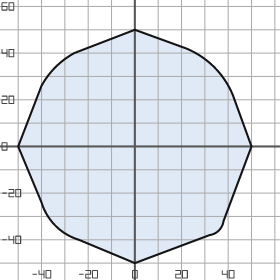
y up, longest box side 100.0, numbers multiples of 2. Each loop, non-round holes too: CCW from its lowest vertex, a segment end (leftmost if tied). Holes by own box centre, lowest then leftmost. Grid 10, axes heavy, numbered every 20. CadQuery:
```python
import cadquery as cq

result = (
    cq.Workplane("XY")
    .moveTo(0.0, -50.0)
    .lineTo(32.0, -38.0)
    .threePointArc((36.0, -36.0), (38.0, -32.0))
    .lineTo(50.0, 0.0)
    .lineTo(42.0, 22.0)
    .threePointArc((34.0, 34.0), (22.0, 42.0))
    .lineTo(0.0, 50.0)
    .lineTo(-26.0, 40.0)
    .threePointArc((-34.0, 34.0), (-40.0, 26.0))
    .lineTo(-50.0, 0.0)
    .lineTo(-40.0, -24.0)
    .threePointArc((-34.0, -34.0), (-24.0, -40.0))
    .close()
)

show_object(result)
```